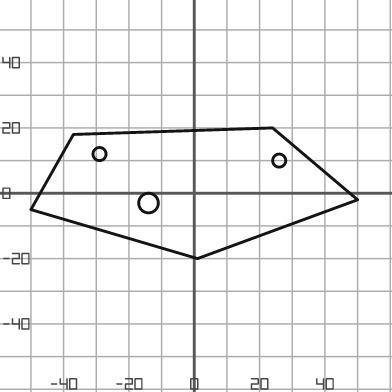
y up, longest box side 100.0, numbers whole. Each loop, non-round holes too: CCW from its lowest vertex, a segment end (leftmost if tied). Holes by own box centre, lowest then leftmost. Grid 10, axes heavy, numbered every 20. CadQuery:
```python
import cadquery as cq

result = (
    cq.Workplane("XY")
    .moveTo(1.0, -20.0)
    .lineTo(50.0, -2.0)
    .lineTo(24.0, 20.0)
    .lineTo(-37.0, 18.0)
    .lineTo(-50.0, -5.0)
    .close()
    .moveTo(-14.0, -3.0)
    .circle(3.0)
    .moveTo(26.0, 10.0)
    .circle(2.0)
    .moveTo(-29.0, 12.0)
    .circle(2.0)
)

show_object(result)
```